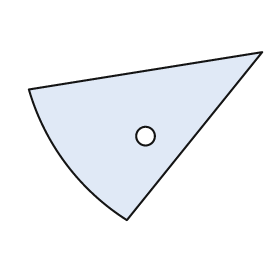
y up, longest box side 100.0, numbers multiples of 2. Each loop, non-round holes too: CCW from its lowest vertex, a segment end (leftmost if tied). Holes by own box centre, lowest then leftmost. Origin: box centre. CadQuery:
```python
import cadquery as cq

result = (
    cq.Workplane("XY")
    .moveTo(-8.0, -36.0)
    .lineTo(50.0, 36.0)
    .lineTo(-50.0, 20.0)
    .threePointArc((-34.0, -12.0), (-8.0, -36.0))
    .close()
    .moveTo(0.0, 0.0)
    .circle(4.0)
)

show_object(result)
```